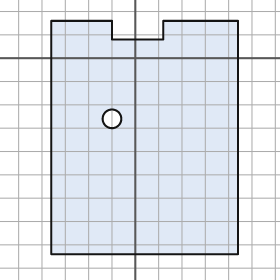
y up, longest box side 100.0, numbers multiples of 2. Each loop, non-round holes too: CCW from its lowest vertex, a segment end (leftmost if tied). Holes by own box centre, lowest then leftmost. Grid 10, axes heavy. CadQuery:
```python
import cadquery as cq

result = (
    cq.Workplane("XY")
    .moveTo(-36.0, -84.0)
    .lineTo(44.0, -84.0)
    .lineTo(44.0, 16.0)
    .lineTo(12.0, 16.0)
    .lineTo(12.0, 8.0)
    .lineTo(-10.0, 8.0)
    .lineTo(-10.0, 16.0)
    .lineTo(-36.0, 16.0)
    .close()
    .moveTo(-10.0, -26.0)
    .circle(4.0)
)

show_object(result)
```